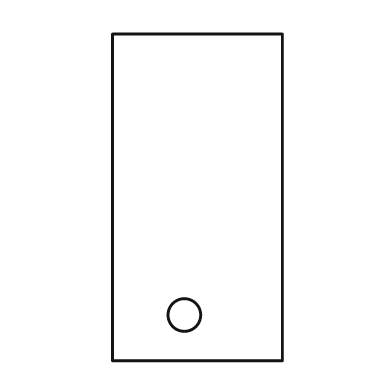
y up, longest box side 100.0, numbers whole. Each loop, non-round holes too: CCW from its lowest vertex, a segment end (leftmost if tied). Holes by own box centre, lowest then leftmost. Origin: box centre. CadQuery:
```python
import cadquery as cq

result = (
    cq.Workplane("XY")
    .moveTo(-26.0, -50.0)
    .lineTo(26.0, -50.0)
    .lineTo(26.0, 50.0)
    .lineTo(-26.0, 50.0)
    .close()
    .moveTo(-4.0, -36.0)
    .circle(5.0)
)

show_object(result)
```